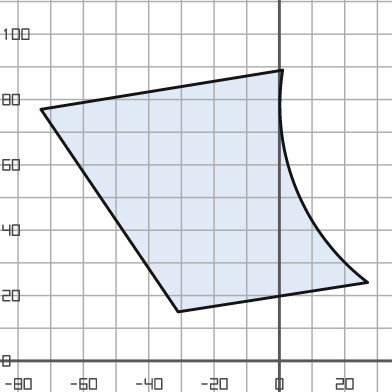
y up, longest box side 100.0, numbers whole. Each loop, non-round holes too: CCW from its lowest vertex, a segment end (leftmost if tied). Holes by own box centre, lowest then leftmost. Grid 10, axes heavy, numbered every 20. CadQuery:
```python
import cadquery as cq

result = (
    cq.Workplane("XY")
    .moveTo(-31.0, 15.0)
    .lineTo(27.0, 24.0)
    .threePointArc((5.0, 53.0), (1.0, 89.0))
    .lineTo(-73.0, 77.0)
    .close()
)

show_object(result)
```